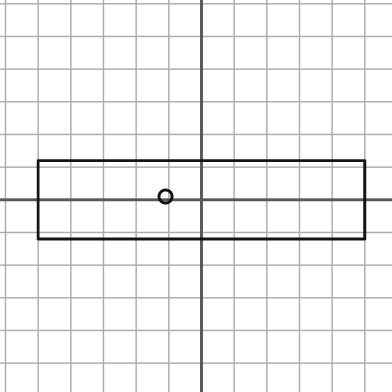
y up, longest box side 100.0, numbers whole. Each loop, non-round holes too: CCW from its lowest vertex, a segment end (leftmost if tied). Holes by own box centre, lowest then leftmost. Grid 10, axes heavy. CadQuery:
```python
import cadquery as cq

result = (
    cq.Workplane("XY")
    .moveTo(-50.0, -12.0)
    .lineTo(50.0, -12.0)
    .lineTo(50.0, 12.0)
    .lineTo(-50.0, 12.0)
    .close()
    .moveTo(-11.0, 1.0)
    .circle(2.0)
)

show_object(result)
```